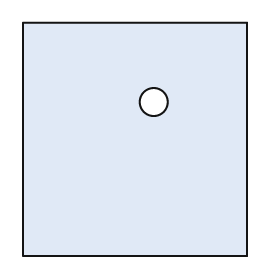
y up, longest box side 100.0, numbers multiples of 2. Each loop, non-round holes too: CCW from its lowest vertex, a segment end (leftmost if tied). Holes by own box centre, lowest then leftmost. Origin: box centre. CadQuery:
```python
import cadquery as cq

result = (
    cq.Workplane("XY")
    .moveTo(-48.0, -50.0)
    .lineTo(48.0, -50.0)
    .lineTo(48.0, 50.0)
    .lineTo(-48.0, 50.0)
    .close()
    .moveTo(8.0, 16.0)
    .circle(6.0)
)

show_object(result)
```